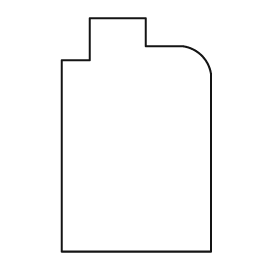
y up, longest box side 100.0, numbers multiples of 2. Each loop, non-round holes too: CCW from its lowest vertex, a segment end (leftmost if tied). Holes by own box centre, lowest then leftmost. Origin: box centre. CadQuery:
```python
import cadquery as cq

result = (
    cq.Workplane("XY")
    .moveTo(-32.0, -50.0)
    .lineTo(32.0, -50.0)
    .lineTo(32.0, 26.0)
    .threePointArc((28.0, 34.0), (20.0, 38.0))
    .lineTo(4.0, 38.0)
    .lineTo(4.0, 50.0)
    .lineTo(-20.0, 50.0)
    .lineTo(-20.0, 32.0)
    .lineTo(-32.0, 32.0)
    .close()
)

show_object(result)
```